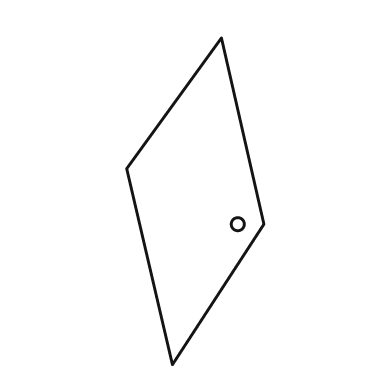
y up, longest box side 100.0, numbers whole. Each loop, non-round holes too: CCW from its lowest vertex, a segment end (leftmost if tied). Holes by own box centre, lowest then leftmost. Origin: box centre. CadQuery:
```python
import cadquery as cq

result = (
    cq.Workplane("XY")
    .moveTo(-7.0, -50.0)
    .lineTo(21.0, -7.0)
    .lineTo(8.0, 50.0)
    .lineTo(-21.0, 10.0)
    .close()
    .moveTo(13.0, -7.0)
    .circle(2.0)
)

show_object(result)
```